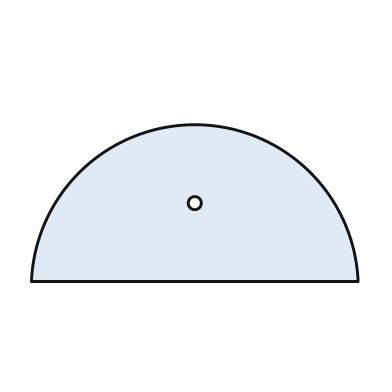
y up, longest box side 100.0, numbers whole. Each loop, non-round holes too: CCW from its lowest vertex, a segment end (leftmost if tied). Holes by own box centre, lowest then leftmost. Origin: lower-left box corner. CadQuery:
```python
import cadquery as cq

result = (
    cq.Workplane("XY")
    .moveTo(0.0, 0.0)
    .lineTo(100.0, 0.0)
    .threePointArc((50.0, 48.0), (0.0, 0.0))
    .close()
    .moveTo(50.0, 24.0)
    .circle(2.0)
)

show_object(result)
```